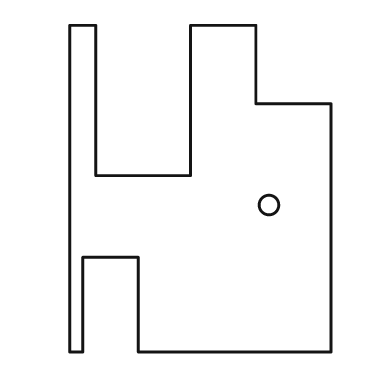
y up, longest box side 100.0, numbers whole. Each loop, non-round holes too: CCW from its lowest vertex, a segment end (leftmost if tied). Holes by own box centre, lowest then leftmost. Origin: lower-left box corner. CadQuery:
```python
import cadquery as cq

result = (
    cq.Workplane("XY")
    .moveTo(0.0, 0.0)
    .lineTo(4.0, 0.0)
    .lineTo(4.0, 29.0)
    .lineTo(21.0, 29.0)
    .lineTo(21.0, 0.0)
    .lineTo(80.0, 0.0)
    .lineTo(80.0, 76.0)
    .lineTo(57.0, 76.0)
    .lineTo(57.0, 100.0)
    .lineTo(37.0, 100.0)
    .lineTo(37.0, 54.0)
    .lineTo(8.0, 54.0)
    .lineTo(8.0, 100.0)
    .lineTo(0.0, 100.0)
    .close()
    .moveTo(61.0, 45.0)
    .circle(3.0)
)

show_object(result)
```